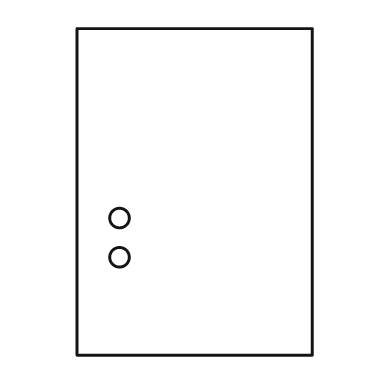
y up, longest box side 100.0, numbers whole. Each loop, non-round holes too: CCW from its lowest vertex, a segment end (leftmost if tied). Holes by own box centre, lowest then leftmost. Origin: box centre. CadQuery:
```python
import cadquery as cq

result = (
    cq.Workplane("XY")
    .moveTo(-36.0, -50.0)
    .lineTo(36.0, -50.0)
    .lineTo(36.0, 50.0)
    .lineTo(-36.0, 50.0)
    .close()
    .moveTo(-23.0, -20.0)
    .circle(3.0)
    .moveTo(-23.0, -8.0)
    .circle(3.0)
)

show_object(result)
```